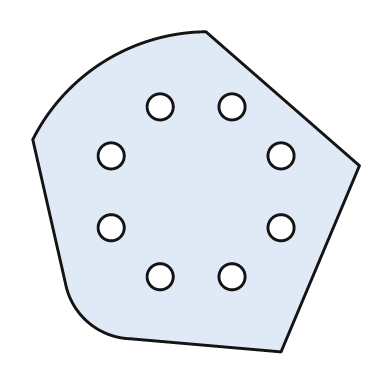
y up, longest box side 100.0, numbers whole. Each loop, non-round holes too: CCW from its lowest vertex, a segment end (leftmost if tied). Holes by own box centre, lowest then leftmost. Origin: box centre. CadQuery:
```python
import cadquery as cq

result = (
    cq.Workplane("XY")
    .moveTo(26.0, -49.0)
    .lineTo(50.0, 8.0)
    .lineTo(3.0, 49.0)
    .threePointArc((-28.0, 40.0), (-50.0, 16.0))
    .lineTo(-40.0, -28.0)
    .threePointArc((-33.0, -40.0), (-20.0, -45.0))
    .close()
    .moveTo(-11.0, -26.0)
    .circle(4.0)
    .moveTo(11.0, -26.0)
    .circle(4.0)
    .moveTo(-26.0, -11.0)
    .circle(4.0)
    .moveTo(26.0, -11.0)
    .circle(4.0)
    .moveTo(-26.0, 11.0)
    .circle(4.0)
    .moveTo(26.0, 11.0)
    .circle(4.0)
    .moveTo(-11.0, 26.0)
    .circle(4.0)
    .moveTo(11.0, 26.0)
    .circle(4.0)
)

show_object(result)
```